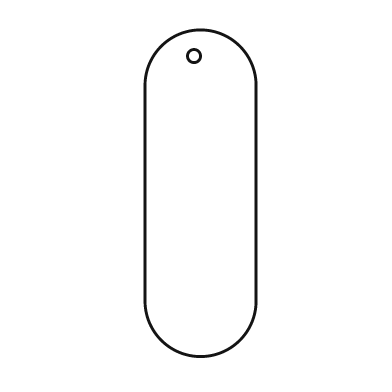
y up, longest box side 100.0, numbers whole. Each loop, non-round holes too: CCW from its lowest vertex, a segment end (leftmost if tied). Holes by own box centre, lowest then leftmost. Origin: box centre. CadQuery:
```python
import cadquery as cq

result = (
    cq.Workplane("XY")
    .moveTo(-17.0, -33.0)
    .threePointArc((0.0, -50.0), (17.0, -33.0))
    .lineTo(17.0, 33.0)
    .threePointArc((0.0, 50.0), (-17.0, 33.0))
    .close()
    .moveTo(-2.0, 42.0)
    .circle(2.0)
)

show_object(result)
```